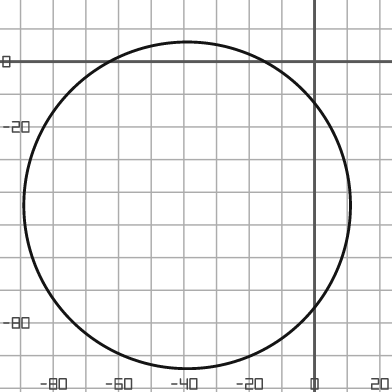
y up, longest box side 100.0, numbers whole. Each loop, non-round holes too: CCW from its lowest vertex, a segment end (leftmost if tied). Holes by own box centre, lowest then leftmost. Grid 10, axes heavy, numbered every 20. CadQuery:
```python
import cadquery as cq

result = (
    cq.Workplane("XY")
    .moveTo(-39.0, -44.0)
    .circle(50.0)
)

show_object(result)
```